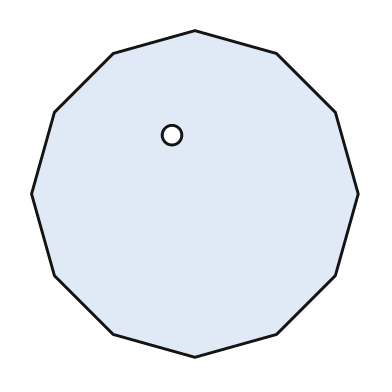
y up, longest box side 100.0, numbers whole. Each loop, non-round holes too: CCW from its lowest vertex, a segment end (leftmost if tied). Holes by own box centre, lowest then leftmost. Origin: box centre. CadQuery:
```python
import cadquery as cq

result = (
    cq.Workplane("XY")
    .moveTo(0.0, -50.0)
    .lineTo(25.0, -43.0)
    .lineTo(43.0, -25.0)
    .lineTo(50.0, 0.0)
    .lineTo(43.0, 25.0)
    .lineTo(25.0, 43.0)
    .lineTo(0.0, 50.0)
    .lineTo(-25.0, 43.0)
    .lineTo(-43.0, 25.0)
    .lineTo(-50.0, 0.0)
    .lineTo(-43.0, -25.0)
    .lineTo(-25.0, -43.0)
    .close()
    .moveTo(-7.0, 18.0)
    .circle(3.0)
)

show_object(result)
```